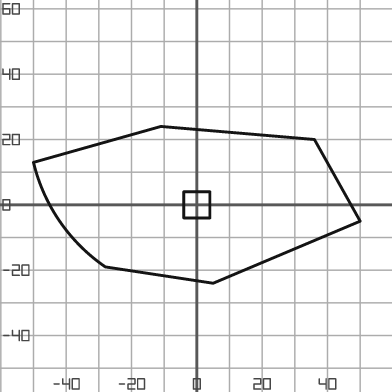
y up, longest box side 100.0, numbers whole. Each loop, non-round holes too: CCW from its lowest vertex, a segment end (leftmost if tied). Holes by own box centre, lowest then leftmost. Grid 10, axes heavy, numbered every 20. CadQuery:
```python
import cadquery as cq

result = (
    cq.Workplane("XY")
    .moveTo(5.0, -24.0)
    .lineTo(50.0, -5.0)
    .lineTo(36.0, 20.0)
    .lineTo(-11.0, 24.0)
    .lineTo(-50.0, 13.0)
    .threePointArc((-42.0, -5.0), (-28.0, -19.0))
    .close()
    .moveTo(-4.0, -4.0)
    .lineTo(4.0, -4.0)
    .lineTo(4.0, 4.0)
    .lineTo(-4.0, 4.0)
    .close()
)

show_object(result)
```